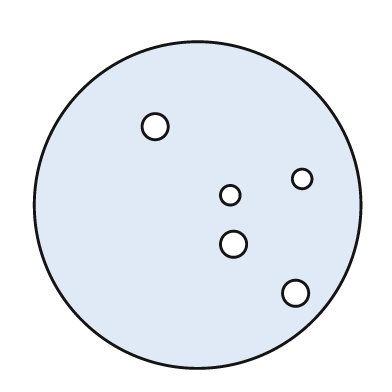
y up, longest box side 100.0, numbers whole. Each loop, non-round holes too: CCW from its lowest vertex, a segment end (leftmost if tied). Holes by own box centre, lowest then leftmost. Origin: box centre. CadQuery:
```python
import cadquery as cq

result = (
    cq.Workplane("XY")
    .moveTo(0.0, 0.0)
    .circle(50.0)
    .moveTo(30.0, -27.0)
    .circle(4.0)
    .moveTo(11.0, -12.0)
    .circle(4.0)
    .moveTo(10.0, 3.0)
    .circle(3.0)
    .moveTo(32.0, 8.0)
    .circle(3.0)
    .moveTo(-13.0, 24.0)
    .circle(4.0)
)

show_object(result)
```